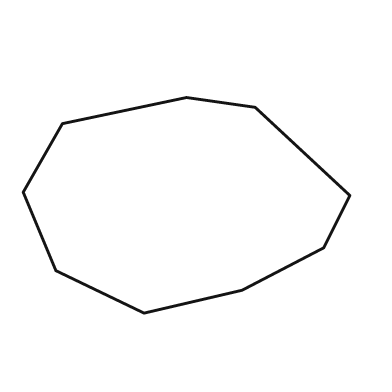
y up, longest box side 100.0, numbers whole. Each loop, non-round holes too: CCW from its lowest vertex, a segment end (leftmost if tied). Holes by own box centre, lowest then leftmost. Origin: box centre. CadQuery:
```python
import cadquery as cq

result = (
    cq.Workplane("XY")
    .moveTo(-13.0, -33.0)
    .lineTo(17.0, -26.0)
    .lineTo(42.0, -13.0)
    .lineTo(50.0, 3.0)
    .lineTo(21.0, 30.0)
    .lineTo(0.0, 33.0)
    .lineTo(-38.0, 25.0)
    .lineTo(-50.0, 4.0)
    .lineTo(-40.0, -20.0)
    .close()
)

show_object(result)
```